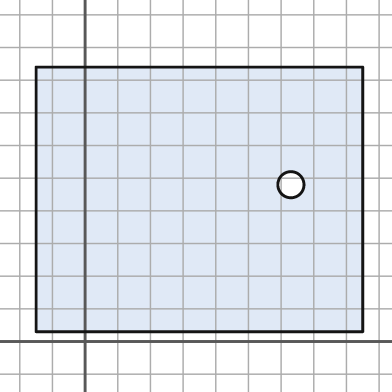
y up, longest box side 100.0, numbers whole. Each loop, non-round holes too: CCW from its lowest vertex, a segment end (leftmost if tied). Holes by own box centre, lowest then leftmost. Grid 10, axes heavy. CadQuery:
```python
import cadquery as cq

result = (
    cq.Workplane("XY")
    .moveTo(-15.0, 3.0)
    .lineTo(85.0, 3.0)
    .lineTo(85.0, 84.0)
    .lineTo(-15.0, 84.0)
    .close()
    .moveTo(63.0, 48.0)
    .circle(4.0)
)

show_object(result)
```